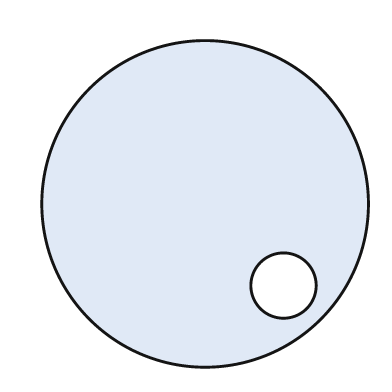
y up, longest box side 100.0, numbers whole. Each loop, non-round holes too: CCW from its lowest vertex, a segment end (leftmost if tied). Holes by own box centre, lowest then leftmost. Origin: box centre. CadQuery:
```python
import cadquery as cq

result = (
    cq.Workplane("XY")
    .moveTo(0.0, 0.0)
    .circle(50.0)
    .moveTo(24.0, -25.0)
    .circle(10.0)
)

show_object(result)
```